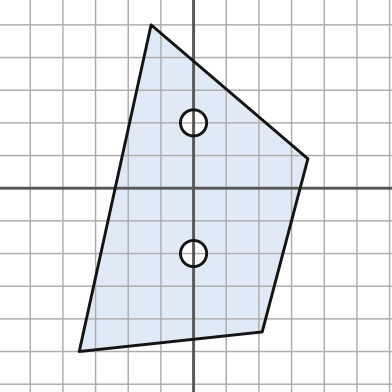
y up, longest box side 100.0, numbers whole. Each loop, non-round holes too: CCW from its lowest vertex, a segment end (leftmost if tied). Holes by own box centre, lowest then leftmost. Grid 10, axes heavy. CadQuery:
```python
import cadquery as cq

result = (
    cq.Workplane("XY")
    .moveTo(-35.0, -50.0)
    .lineTo(21.0, -44.0)
    .lineTo(35.0, 9.0)
    .lineTo(-13.0, 50.0)
    .close()
    .moveTo(0.0, -20.0)
    .circle(4.0)
    .moveTo(0.0, 20.0)
    .circle(4.0)
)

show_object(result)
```